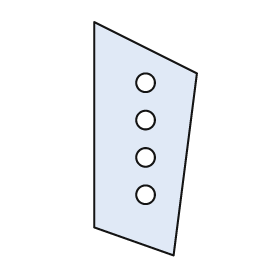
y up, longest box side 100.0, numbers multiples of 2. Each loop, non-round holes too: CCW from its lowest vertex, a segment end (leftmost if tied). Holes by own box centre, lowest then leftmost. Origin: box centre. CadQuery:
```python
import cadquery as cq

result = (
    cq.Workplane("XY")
    .moveTo(12.0, -50.0)
    .lineTo(22.0, 28.0)
    .lineTo(-22.0, 50.0)
    .lineTo(-22.0, -38.0)
    .close()
    .moveTo(0.0, -24.0)
    .circle(4.0)
    .moveTo(0.0, -8.0)
    .circle(4.0)
    .moveTo(0.0, 8.0)
    .circle(4.0)
    .moveTo(0.0, 24.0)
    .circle(4.0)
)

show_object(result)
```